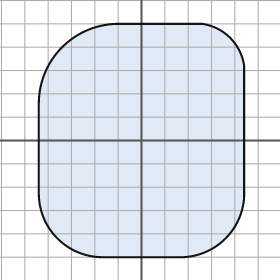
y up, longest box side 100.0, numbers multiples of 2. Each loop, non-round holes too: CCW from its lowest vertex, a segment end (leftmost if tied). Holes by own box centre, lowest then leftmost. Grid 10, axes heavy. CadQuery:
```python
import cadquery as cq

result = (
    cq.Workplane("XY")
    .moveTo(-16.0, -50.0)
    .lineTo(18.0, -50.0)
    .threePointArc((36.0, -42.0), (44.0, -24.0))
    .lineTo(44.0, 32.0)
    .threePointArc((38.0, 44.0), (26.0, 50.0))
    .lineTo(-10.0, 50.0)
    .threePointArc((-34.0, 40.0), (-44.0, 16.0))
    .lineTo(-44.0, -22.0)
    .threePointArc((-36.0, -42.0), (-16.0, -50.0))
    .close()
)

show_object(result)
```